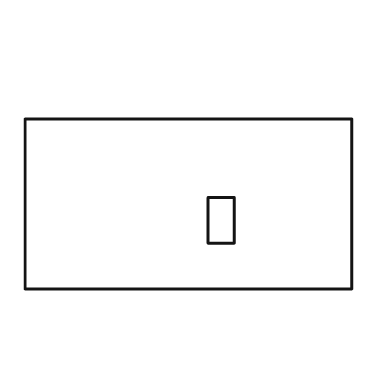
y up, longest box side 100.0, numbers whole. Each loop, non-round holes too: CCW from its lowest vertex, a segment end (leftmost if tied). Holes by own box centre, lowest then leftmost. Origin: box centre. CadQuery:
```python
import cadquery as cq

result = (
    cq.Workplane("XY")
    .moveTo(-50.0, -26.0)
    .lineTo(50.0, -26.0)
    .lineTo(50.0, 26.0)
    .lineTo(-50.0, 26.0)
    .close()
    .moveTo(6.0, -12.0)
    .lineTo(14.0, -12.0)
    .lineTo(14.0, 2.0)
    .lineTo(6.0, 2.0)
    .close()
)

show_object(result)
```